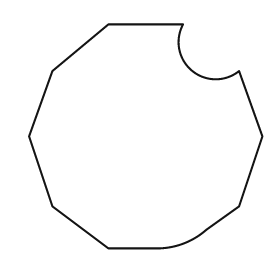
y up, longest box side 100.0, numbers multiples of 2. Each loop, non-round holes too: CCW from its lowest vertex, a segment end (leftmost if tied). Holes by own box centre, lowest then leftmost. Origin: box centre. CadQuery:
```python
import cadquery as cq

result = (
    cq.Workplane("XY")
    .moveTo(-16.0, -48.0)
    .lineTo(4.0, -48.0)
    .threePointArc((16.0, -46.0), (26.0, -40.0))
    .lineTo(40.0, -30.0)
    .lineTo(50.0, 0.0)
    .lineTo(40.0, 28.0)
    .threePointArc((20.0, 28.0), (16.0, 48.0))
    .lineTo(-16.0, 48.0)
    .lineTo(-40.0, 28.0)
    .lineTo(-50.0, 0.0)
    .lineTo(-40.0, -30.0)
    .close()
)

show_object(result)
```